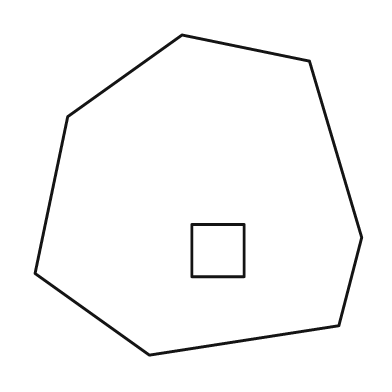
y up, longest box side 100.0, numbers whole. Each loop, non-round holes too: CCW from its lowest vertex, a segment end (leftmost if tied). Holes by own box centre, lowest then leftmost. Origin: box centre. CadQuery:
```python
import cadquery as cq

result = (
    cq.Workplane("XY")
    .moveTo(-15.0, -49.0)
    .lineTo(43.0, -40.0)
    .lineTo(50.0, -13.0)
    .lineTo(34.0, 41.0)
    .lineTo(-5.0, 49.0)
    .lineTo(-40.0, 24.0)
    .lineTo(-50.0, -24.0)
    .close()
    .moveTo(-2.0, -25.0)
    .lineTo(14.0, -25.0)
    .lineTo(14.0, -9.0)
    .lineTo(-2.0, -9.0)
    .close()
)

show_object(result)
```